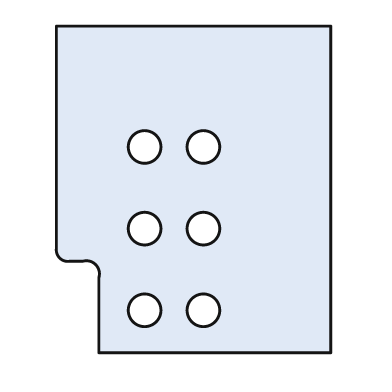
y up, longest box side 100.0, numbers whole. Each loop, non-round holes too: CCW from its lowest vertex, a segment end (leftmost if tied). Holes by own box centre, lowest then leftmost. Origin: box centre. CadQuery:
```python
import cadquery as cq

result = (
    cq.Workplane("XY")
    .moveTo(-29.0, -50.0)
    .lineTo(42.0, -50.0)
    .lineTo(42.0, 50.0)
    .lineTo(-42.0, 50.0)
    .lineTo(-42.0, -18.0)
    .threePointArc((-41.0, -21.0), (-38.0, -22.0))
    .lineTo(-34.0, -22.0)
    .threePointArc((-30.0, -23.0), (-29.0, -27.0))
    .close()
    .moveTo(-15.0, -37.0)
    .circle(5.0)
    .moveTo(3.0, -37.0)
    .circle(5.0)
    .moveTo(-15.0, -12.0)
    .circle(5.0)
    .moveTo(3.0, -12.0)
    .circle(5.0)
    .moveTo(-15.0, 13.0)
    .circle(5.0)
    .moveTo(3.0, 13.0)
    .circle(5.0)
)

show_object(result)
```